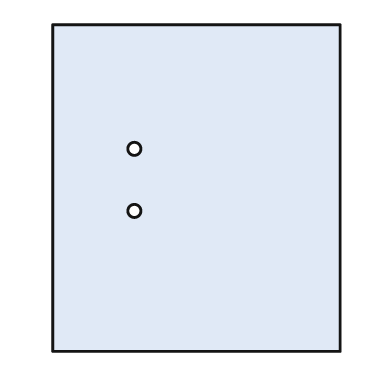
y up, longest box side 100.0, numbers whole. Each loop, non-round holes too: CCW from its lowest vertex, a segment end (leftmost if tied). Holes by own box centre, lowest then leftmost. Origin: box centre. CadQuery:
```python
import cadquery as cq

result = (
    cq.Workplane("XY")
    .moveTo(-44.0, -50.0)
    .lineTo(44.0, -50.0)
    .lineTo(44.0, 50.0)
    .lineTo(-44.0, 50.0)
    .close()
    .moveTo(-19.0, -7.0)
    .circle(2.0)
    .moveTo(-19.0, 12.0)
    .circle(2.0)
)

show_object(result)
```